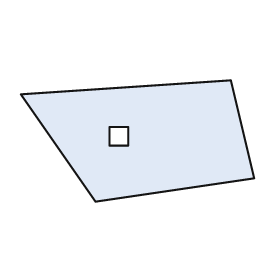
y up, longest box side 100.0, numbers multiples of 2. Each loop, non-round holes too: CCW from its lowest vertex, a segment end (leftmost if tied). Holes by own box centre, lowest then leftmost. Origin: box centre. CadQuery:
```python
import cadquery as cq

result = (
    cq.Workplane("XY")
    .moveTo(-18.0, -26.0)
    .lineTo(50.0, -16.0)
    .lineTo(40.0, 26.0)
    .lineTo(-50.0, 20.0)
    .close()
    .moveTo(-12.0, -2.0)
    .lineTo(-4.0, -2.0)
    .lineTo(-4.0, 6.0)
    .lineTo(-12.0, 6.0)
    .close()
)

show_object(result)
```